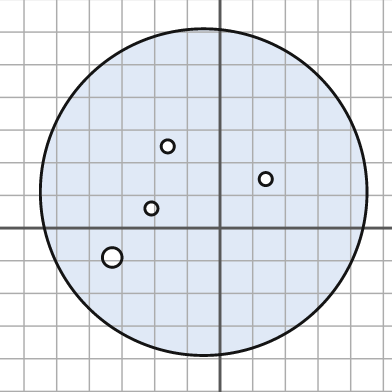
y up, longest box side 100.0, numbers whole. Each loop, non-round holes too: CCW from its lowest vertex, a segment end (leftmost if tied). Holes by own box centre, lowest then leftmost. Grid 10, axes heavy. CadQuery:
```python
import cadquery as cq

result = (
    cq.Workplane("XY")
    .moveTo(-5.0, 11.0)
    .circle(50.0)
    .moveTo(-33.0, -9.0)
    .circle(3.0)
    .moveTo(-21.0, 6.0)
    .circle(2.0)
    .moveTo(14.0, 15.0)
    .circle(2.0)
    .moveTo(-16.0, 25.0)
    .circle(2.0)
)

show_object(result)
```